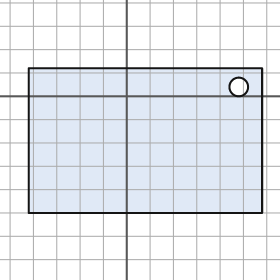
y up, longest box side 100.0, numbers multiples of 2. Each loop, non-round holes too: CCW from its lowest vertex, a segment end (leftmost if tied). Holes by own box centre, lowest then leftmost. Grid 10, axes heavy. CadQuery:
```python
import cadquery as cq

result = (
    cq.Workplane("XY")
    .moveTo(-42.0, -50.0)
    .lineTo(58.0, -50.0)
    .lineTo(58.0, 12.0)
    .lineTo(-42.0, 12.0)
    .close()
    .moveTo(48.0, 4.0)
    .circle(4.0)
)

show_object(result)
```